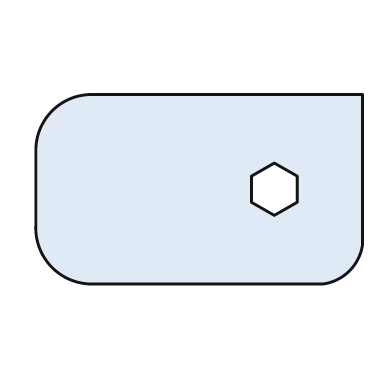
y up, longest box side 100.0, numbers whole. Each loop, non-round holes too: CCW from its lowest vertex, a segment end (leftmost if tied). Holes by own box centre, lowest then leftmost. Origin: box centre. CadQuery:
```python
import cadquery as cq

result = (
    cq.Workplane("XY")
    .moveTo(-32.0, -29.0)
    .lineTo(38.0, -29.0)
    .threePointArc((46.0, -25.0), (50.0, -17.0))
    .lineTo(50.0, 29.0)
    .lineTo(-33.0, 29.0)
    .threePointArc((-45.0, 24.0), (-50.0, 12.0))
    .lineTo(-50.0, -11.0)
    .threePointArc((-45.0, -24.0), (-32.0, -29.0))
    .close()
    .moveTo(23.0, -8.0)
    .lineTo(30.0, -4.0)
    .lineTo(30.0, 4.0)
    .lineTo(23.0, 8.0)
    .lineTo(16.0, 4.0)
    .lineTo(16.0, -4.0)
    .close()
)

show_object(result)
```